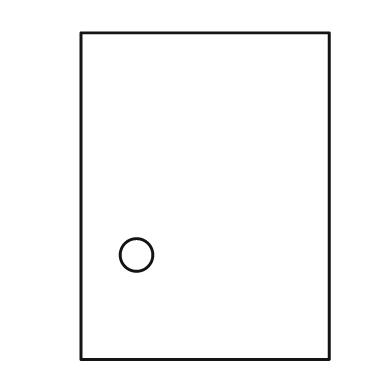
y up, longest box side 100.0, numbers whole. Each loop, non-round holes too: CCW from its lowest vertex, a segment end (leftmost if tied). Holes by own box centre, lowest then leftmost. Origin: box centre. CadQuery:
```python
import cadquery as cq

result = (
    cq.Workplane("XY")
    .moveTo(-38.0, -50.0)
    .lineTo(38.0, -50.0)
    .lineTo(38.0, 50.0)
    .lineTo(-38.0, 50.0)
    .close()
    .moveTo(-21.0, -18.0)
    .circle(5.0)
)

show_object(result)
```